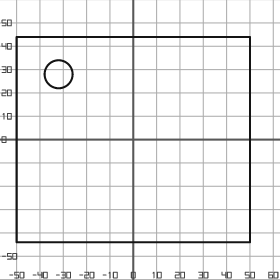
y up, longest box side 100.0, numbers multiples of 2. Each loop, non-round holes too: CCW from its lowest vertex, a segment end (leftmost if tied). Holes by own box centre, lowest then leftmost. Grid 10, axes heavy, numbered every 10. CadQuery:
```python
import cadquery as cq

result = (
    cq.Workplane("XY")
    .moveTo(-50.0, -44.0)
    .lineTo(50.0, -44.0)
    .lineTo(50.0, 44.0)
    .lineTo(-50.0, 44.0)
    .close()
    .moveTo(-32.0, 28.0)
    .circle(6.0)
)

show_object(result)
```